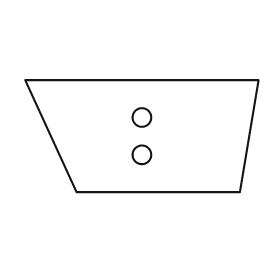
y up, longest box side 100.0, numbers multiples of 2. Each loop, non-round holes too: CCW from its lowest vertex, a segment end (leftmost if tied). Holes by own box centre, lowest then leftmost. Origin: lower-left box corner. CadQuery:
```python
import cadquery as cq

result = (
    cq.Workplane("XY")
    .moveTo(22.0, 0.0)
    .lineTo(92.0, 0.0)
    .lineTo(100.0, 48.0)
    .lineTo(0.0, 48.0)
    .close()
    .moveTo(50.0, 16.0)
    .circle(4.0)
    .moveTo(50.0, 32.0)
    .circle(4.0)
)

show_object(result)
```